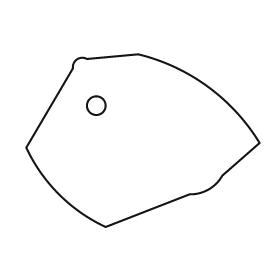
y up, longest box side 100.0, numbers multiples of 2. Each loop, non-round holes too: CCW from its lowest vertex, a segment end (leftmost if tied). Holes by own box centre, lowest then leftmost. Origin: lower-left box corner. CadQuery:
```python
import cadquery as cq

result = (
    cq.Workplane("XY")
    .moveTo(34.0, 0.0)
    .lineTo(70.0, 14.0)
    .threePointArc((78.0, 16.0), (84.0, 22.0))
    .lineTo(100.0, 36.0)
    .threePointArc((78.0, 60.0), (48.0, 74.0))
    .lineTo(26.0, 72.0)
    .threePointArc((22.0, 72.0), (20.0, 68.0))
    .lineTo(0.0, 34.0)
    .threePointArc((14.0, 14.0), (34.0, 0.0))
    .close()
    .moveTo(30.0, 52.0)
    .circle(4.0)
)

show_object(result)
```